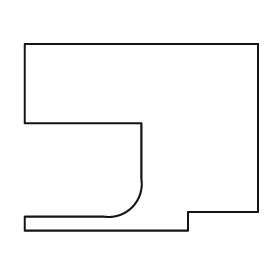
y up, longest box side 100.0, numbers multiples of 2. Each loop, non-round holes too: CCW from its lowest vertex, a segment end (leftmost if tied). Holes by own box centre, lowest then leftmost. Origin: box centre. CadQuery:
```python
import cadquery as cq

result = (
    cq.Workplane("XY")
    .moveTo(-50.0, -40.0)
    .lineTo(20.0, -40.0)
    .lineTo(20.0, -32.0)
    .lineTo(50.0, -32.0)
    .lineTo(50.0, 40.0)
    .lineTo(-50.0, 40.0)
    .lineTo(-50.0, 6.0)
    .lineTo(0.0, 6.0)
    .lineTo(0.0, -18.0)
    .threePointArc((-4.0, -30.0), (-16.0, -34.0))
    .lineTo(-50.0, -34.0)
    .close()
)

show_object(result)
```